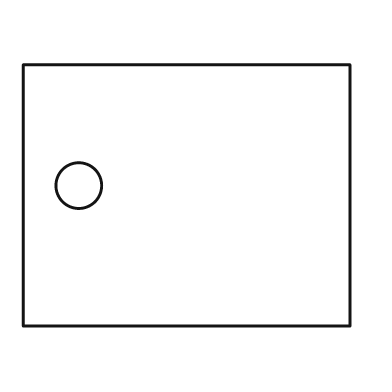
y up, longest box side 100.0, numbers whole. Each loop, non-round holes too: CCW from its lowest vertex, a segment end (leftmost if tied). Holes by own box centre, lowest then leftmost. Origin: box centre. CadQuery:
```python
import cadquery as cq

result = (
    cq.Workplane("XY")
    .moveTo(-50.0, -40.0)
    .lineTo(50.0, -40.0)
    .lineTo(50.0, 40.0)
    .lineTo(-50.0, 40.0)
    .close()
    .moveTo(-33.0, 3.0)
    .circle(7.0)
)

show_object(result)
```